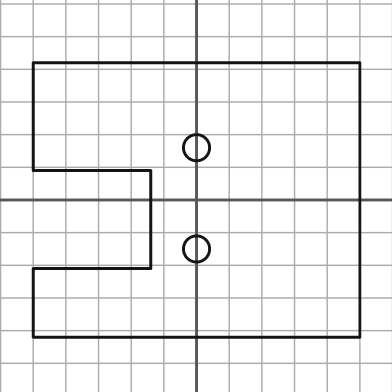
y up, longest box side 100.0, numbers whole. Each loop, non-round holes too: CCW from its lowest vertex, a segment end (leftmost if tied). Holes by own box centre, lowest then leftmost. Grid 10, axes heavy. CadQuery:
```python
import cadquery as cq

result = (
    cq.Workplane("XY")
    .moveTo(-50.0, -42.0)
    .lineTo(50.0, -42.0)
    .lineTo(50.0, 42.0)
    .lineTo(-50.0, 42.0)
    .lineTo(-50.0, 9.0)
    .lineTo(-14.0, 9.0)
    .lineTo(-14.0, -21.0)
    .lineTo(-50.0, -21.0)
    .close()
    .moveTo(0.0, -15.0)
    .circle(4.0)
    .moveTo(0.0, 16.0)
    .circle(4.0)
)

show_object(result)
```